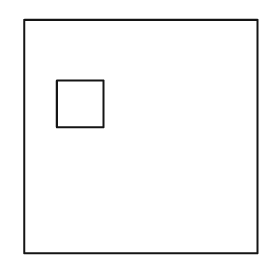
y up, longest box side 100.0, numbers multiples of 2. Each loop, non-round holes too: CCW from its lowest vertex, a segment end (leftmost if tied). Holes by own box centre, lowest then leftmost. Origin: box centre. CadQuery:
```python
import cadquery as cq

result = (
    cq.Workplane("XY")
    .moveTo(-50.0, -50.0)
    .lineTo(50.0, -50.0)
    .lineTo(50.0, 50.0)
    .lineTo(-50.0, 50.0)
    .close()
    .moveTo(-36.0, 4.0)
    .lineTo(-16.0, 4.0)
    .lineTo(-16.0, 24.0)
    .lineTo(-36.0, 24.0)
    .close()
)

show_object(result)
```